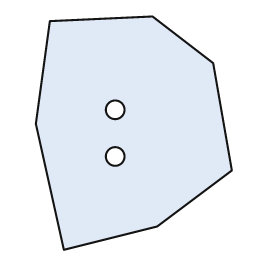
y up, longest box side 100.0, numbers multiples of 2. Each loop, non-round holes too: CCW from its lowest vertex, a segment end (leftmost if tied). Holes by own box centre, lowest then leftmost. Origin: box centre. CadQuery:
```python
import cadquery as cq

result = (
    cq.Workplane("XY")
    .moveTo(-30.0, -50.0)
    .lineTo(10.0, -40.0)
    .lineTo(42.0, -16.0)
    .lineTo(34.0, 30.0)
    .lineTo(8.0, 50.0)
    .lineTo(-36.0, 48.0)
    .lineTo(-42.0, 4.0)
    .close()
    .moveTo(-8.0, -10.0)
    .circle(4.0)
    .moveTo(-8.0, 10.0)
    .circle(4.0)
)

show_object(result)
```